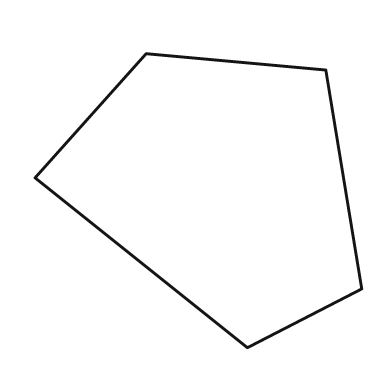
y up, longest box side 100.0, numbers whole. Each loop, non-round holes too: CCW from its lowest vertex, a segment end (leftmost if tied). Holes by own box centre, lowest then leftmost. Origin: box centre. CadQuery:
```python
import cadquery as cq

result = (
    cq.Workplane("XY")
    .moveTo(15.0, -45.0)
    .lineTo(50.0, -27.0)
    .lineTo(39.0, 40.0)
    .lineTo(-16.0, 45.0)
    .lineTo(-50.0, 7.0)
    .close()
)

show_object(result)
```